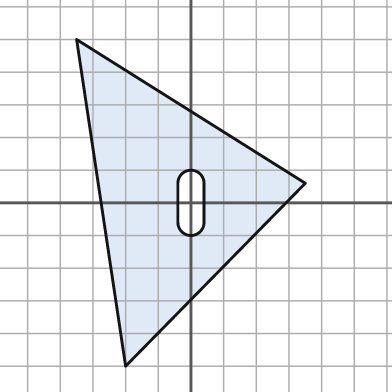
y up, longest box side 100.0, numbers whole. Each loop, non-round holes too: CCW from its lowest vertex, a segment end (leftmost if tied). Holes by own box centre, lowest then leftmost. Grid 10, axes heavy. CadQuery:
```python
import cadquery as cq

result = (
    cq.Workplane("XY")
    .moveTo(-20.0, -50.0)
    .lineTo(35.0, 6.0)
    .lineTo(-35.0, 50.0)
    .close()
    .moveTo(-4.0, -6.0)
    .threePointArc((0.0, -10.0), (4.0, -6.0))
    .lineTo(4.0, 6.0)
    .threePointArc((0.0, 10.0), (-4.0, 6.0))
    .close()
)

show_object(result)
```